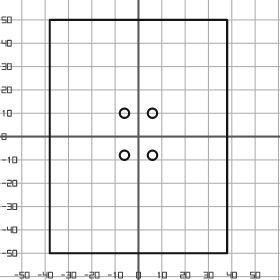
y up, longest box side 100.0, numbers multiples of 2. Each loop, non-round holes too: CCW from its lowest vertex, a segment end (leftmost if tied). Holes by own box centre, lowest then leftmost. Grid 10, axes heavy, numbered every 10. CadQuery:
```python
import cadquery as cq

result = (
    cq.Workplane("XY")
    .moveTo(-38.0, -50.0)
    .lineTo(38.0, -50.0)
    .lineTo(38.0, 50.0)
    .lineTo(-38.0, 50.0)
    .close()
    .moveTo(-6.0, -8.0)
    .circle(2.0)
    .moveTo(6.0, -8.0)
    .circle(2.0)
    .moveTo(-6.0, 10.0)
    .circle(2.0)
    .moveTo(6.0, 10.0)
    .circle(2.0)
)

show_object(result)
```